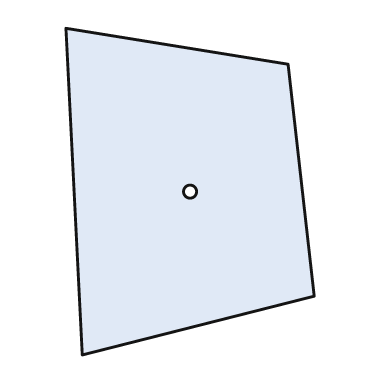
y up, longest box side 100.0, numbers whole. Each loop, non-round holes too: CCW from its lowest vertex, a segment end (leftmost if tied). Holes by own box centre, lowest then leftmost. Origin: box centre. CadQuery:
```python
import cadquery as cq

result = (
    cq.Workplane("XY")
    .moveTo(-33.0, -50.0)
    .lineTo(38.0, -32.0)
    .lineTo(30.0, 39.0)
    .lineTo(-38.0, 50.0)
    .close()
    .moveTo(0.0, 0.0)
    .circle(2.0)
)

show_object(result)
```